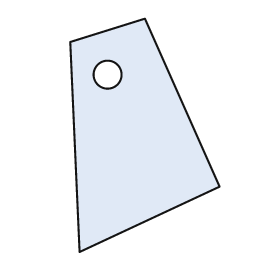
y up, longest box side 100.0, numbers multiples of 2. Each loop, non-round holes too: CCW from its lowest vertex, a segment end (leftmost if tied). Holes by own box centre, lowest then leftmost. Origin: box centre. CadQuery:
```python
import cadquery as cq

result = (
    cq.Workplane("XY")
    .moveTo(-28.0, -50.0)
    .lineTo(32.0, -22.0)
    .lineTo(0.0, 50.0)
    .lineTo(-32.0, 40.0)
    .close()
    .moveTo(-16.0, 26.0)
    .circle(6.0)
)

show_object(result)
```